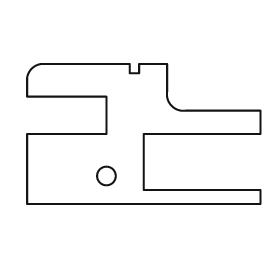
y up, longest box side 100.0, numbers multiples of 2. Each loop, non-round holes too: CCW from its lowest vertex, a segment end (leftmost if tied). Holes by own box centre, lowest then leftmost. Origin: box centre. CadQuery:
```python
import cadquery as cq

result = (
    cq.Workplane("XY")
    .moveTo(-50.0, -30.0)
    .lineTo(50.0, -30.0)
    .lineTo(50.0, -24.0)
    .lineTo(0.0, -24.0)
    .lineTo(0.0, 0.0)
    .lineTo(50.0, 0.0)
    .lineTo(50.0, 10.0)
    .lineTo(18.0, 10.0)
    .threePointArc((12.0, 12.0), (10.0, 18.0))
    .lineTo(10.0, 30.0)
    .lineTo(-2.0, 30.0)
    .lineTo(-2.0, 26.0)
    .lineTo(-6.0, 26.0)
    .lineTo(-6.0, 30.0)
    .lineTo(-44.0, 30.0)
    .threePointArc((-48.0, 28.0), (-50.0, 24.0))
    .lineTo(-50.0, 16.0)
    .lineTo(-16.0, 16.0)
    .lineTo(-16.0, 0.0)
    .lineTo(-50.0, 0.0)
    .close()
    .moveTo(-16.0, -18.0)
    .circle(4.0)
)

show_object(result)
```